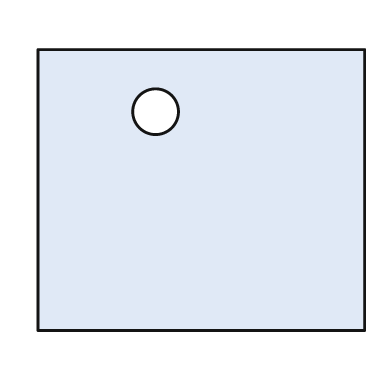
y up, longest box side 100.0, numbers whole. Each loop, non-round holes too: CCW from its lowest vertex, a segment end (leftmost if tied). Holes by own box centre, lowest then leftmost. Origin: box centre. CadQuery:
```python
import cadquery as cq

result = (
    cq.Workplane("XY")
    .moveTo(-50.0, -43.0)
    .lineTo(50.0, -43.0)
    .lineTo(50.0, 43.0)
    .lineTo(-50.0, 43.0)
    .close()
    .moveTo(-14.0, 24.0)
    .circle(7.0)
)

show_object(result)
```